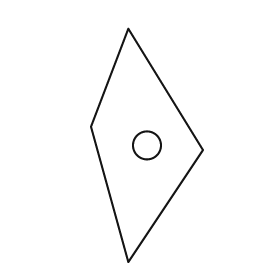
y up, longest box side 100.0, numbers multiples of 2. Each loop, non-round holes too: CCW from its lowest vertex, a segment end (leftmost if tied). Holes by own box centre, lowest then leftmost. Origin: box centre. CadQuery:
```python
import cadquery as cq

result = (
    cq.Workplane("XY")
    .moveTo(-8.0, -50.0)
    .lineTo(24.0, -2.0)
    .lineTo(-8.0, 50.0)
    .lineTo(-24.0, 8.0)
    .close()
    .moveTo(0.0, 0.0)
    .circle(6.0)
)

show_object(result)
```